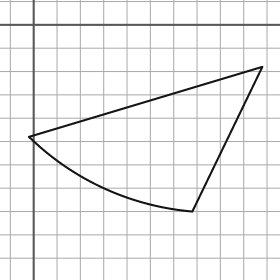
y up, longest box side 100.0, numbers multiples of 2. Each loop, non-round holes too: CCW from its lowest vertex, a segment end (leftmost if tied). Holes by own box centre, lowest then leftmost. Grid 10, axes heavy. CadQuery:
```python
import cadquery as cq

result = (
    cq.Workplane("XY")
    .moveTo(68.0, -80.0)
    .lineTo(98.0, -18.0)
    .lineTo(-2.0, -48.0)
    .threePointArc((30.0, -70.0), (68.0, -80.0))
    .close()
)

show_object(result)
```